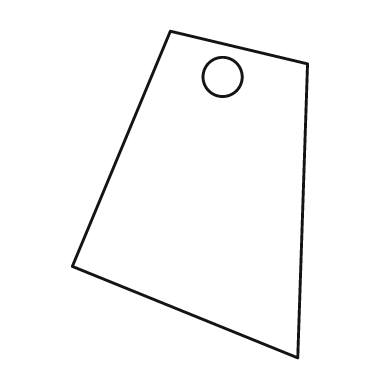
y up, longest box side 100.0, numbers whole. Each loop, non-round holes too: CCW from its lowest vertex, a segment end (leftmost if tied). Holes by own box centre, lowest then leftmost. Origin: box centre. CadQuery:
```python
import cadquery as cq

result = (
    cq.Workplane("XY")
    .moveTo(33.0, -50.0)
    .lineTo(36.0, 40.0)
    .lineTo(-6.0, 50.0)
    .lineTo(-36.0, -22.0)
    .close()
    .moveTo(10.0, 36.0)
    .circle(6.0)
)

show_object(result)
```